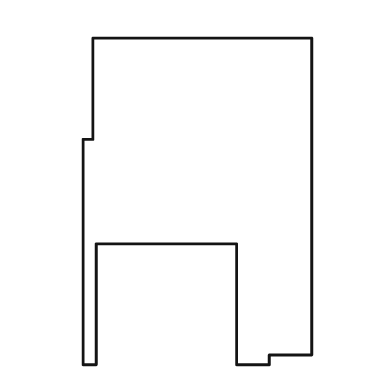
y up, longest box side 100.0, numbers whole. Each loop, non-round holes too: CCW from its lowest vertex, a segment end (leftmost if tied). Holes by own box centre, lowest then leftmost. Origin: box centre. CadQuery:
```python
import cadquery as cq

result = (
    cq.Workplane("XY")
    .moveTo(-35.0, -50.0)
    .lineTo(-31.0, -50.0)
    .lineTo(-31.0, -13.0)
    .lineTo(12.0, -13.0)
    .lineTo(12.0, -50.0)
    .lineTo(22.0, -50.0)
    .lineTo(22.0, -47.0)
    .lineTo(35.0, -47.0)
    .lineTo(35.0, 50.0)
    .lineTo(-32.0, 50.0)
    .lineTo(-32.0, 19.0)
    .lineTo(-35.0, 19.0)
    .close()
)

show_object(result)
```